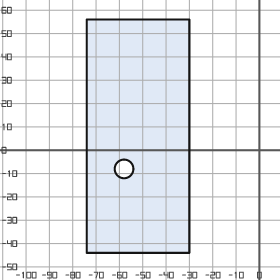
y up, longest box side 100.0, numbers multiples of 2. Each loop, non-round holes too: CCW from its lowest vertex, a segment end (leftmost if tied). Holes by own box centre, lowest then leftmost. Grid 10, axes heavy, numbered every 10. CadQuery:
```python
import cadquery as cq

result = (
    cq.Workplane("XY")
    .moveTo(-74.0, -44.0)
    .lineTo(-30.0, -44.0)
    .lineTo(-30.0, 56.0)
    .lineTo(-74.0, 56.0)
    .close()
    .moveTo(-58.0, -8.0)
    .circle(4.0)
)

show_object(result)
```